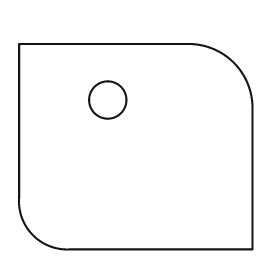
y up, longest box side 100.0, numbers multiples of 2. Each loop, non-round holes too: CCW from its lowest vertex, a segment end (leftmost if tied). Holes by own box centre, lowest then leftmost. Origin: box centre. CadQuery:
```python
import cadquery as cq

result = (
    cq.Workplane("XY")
    .moveTo(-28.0, -44.0)
    .lineTo(50.0, -44.0)
    .lineTo(50.0, 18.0)
    .threePointArc((42.0, 36.0), (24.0, 44.0))
    .lineTo(-50.0, 44.0)
    .lineTo(-50.0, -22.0)
    .threePointArc((-44.0, -38.0), (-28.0, -44.0))
    .close()
    .moveTo(-12.0, 20.0)
    .circle(8.0)
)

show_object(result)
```